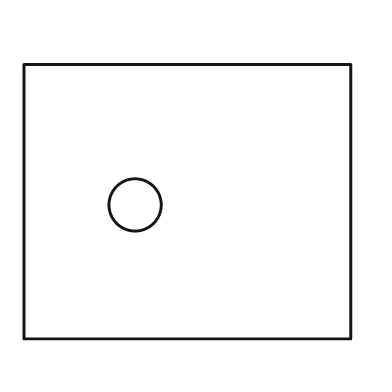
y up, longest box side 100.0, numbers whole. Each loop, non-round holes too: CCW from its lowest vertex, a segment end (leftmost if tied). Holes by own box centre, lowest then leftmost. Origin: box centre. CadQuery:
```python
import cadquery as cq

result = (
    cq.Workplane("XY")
    .moveTo(-50.0, -42.0)
    .lineTo(50.0, -42.0)
    .lineTo(50.0, 42.0)
    .lineTo(-50.0, 42.0)
    .close()
    .moveTo(-16.0, -1.0)
    .circle(8.0)
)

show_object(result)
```